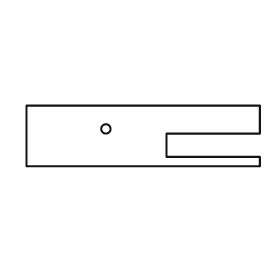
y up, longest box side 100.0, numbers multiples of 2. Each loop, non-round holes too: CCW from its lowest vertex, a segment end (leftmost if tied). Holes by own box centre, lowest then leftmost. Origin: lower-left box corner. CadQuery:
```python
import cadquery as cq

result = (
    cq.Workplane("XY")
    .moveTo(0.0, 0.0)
    .lineTo(100.0, 0.0)
    .lineTo(100.0, 4.0)
    .lineTo(60.0, 4.0)
    .lineTo(60.0, 14.0)
    .lineTo(100.0, 14.0)
    .lineTo(100.0, 26.0)
    .lineTo(0.0, 26.0)
    .close()
    .moveTo(34.0, 16.0)
    .circle(2.0)
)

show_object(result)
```